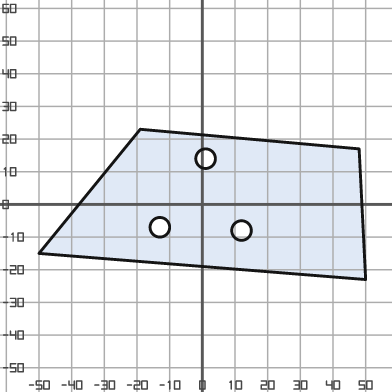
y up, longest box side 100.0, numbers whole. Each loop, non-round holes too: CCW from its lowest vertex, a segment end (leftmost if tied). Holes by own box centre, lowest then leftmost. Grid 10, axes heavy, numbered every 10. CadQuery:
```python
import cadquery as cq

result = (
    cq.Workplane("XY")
    .moveTo(50.0, -23.0)
    .lineTo(48.0, 17.0)
    .lineTo(-19.0, 23.0)
    .lineTo(-50.0, -15.0)
    .close()
    .moveTo(12.0, -8.0)
    .circle(3.0)
    .moveTo(-13.0, -7.0)
    .circle(3.0)
    .moveTo(1.0, 14.0)
    .circle(3.0)
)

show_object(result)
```